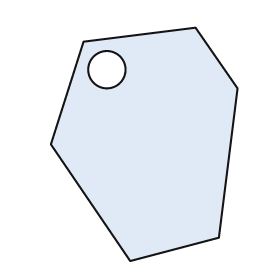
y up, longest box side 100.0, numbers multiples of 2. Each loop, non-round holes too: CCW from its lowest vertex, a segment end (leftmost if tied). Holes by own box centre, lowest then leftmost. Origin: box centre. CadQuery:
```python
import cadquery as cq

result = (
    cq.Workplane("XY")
    .moveTo(-6.0, -50.0)
    .lineTo(32.0, -40.0)
    .lineTo(40.0, 24.0)
    .lineTo(22.0, 50.0)
    .lineTo(-26.0, 44.0)
    .lineTo(-40.0, 0.0)
    .close()
    .moveTo(-16.0, 32.0)
    .circle(8.0)
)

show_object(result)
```